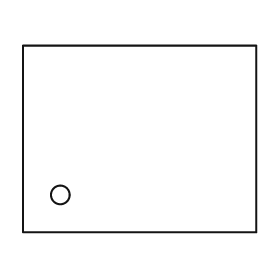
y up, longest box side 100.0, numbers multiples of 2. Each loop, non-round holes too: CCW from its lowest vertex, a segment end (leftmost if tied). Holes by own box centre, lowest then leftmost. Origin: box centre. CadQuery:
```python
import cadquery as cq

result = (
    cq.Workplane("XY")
    .moveTo(-50.0, -40.0)
    .lineTo(50.0, -40.0)
    .lineTo(50.0, 40.0)
    .lineTo(-50.0, 40.0)
    .close()
    .moveTo(-34.0, -24.0)
    .circle(4.0)
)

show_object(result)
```